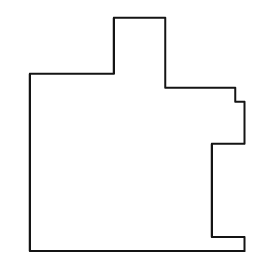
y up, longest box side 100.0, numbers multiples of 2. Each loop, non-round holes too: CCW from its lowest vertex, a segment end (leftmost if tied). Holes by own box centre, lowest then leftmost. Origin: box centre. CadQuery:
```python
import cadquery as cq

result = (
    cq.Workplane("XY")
    .moveTo(-46.0, -50.0)
    .lineTo(46.0, -50.0)
    .lineTo(46.0, -44.0)
    .lineTo(32.0, -44.0)
    .lineTo(32.0, -4.0)
    .lineTo(46.0, -4.0)
    .lineTo(46.0, 14.0)
    .lineTo(42.0, 14.0)
    .lineTo(42.0, 20.0)
    .lineTo(12.0, 20.0)
    .lineTo(12.0, 50.0)
    .lineTo(-10.0, 50.0)
    .lineTo(-10.0, 26.0)
    .lineTo(-46.0, 26.0)
    .close()
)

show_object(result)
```